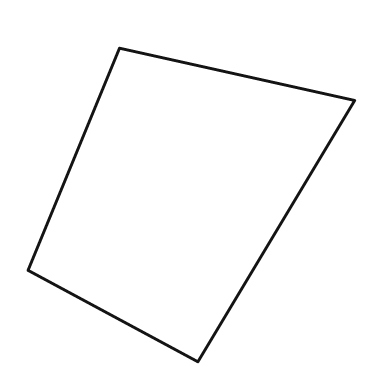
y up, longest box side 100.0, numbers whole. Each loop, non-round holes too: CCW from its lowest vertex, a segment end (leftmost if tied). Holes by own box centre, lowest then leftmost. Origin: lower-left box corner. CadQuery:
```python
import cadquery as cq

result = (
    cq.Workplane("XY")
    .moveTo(52.0, 0.0)
    .lineTo(100.0, 80.0)
    .lineTo(28.0, 96.0)
    .lineTo(0.0, 28.0)
    .close()
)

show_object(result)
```